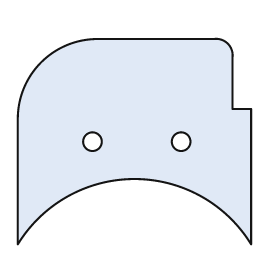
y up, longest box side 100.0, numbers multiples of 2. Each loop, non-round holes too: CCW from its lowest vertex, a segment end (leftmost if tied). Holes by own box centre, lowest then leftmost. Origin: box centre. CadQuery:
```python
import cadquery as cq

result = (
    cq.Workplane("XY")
    .moveTo(-50.0, -44.0)
    .threePointArc((0.0, -16.0), (50.0, -44.0))
    .lineTo(50.0, 14.0)
    .lineTo(42.0, 14.0)
    .lineTo(42.0, 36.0)
    .threePointArc((40.0, 42.0), (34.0, 44.0))
    .lineTo(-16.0, 44.0)
    .threePointArc((-40.0, 34.0), (-50.0, 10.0))
    .close()
    .moveTo(-18.0, 0.0)
    .circle(4.0)
    .moveTo(20.0, 0.0)
    .circle(4.0)
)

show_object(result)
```